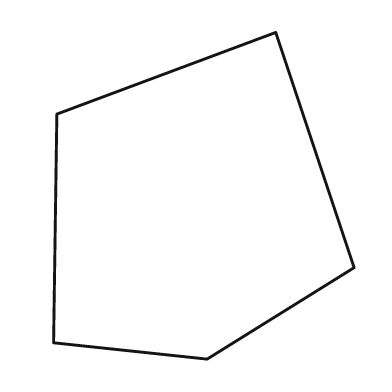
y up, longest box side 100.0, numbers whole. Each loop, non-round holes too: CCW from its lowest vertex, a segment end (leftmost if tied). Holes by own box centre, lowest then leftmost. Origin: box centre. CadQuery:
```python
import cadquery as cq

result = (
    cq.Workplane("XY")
    .moveTo(1.0, -50.0)
    .lineTo(46.0, -22.0)
    .lineTo(22.0, 50.0)
    .lineTo(-45.0, 25.0)
    .lineTo(-46.0, -45.0)
    .close()
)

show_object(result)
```